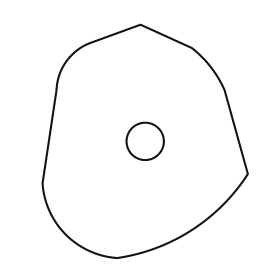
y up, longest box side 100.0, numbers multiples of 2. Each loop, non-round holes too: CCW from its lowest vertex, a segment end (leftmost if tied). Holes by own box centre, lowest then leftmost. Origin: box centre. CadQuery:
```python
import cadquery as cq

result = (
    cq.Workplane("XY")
    .moveTo(-12.0, -50.0)
    .threePointArc((20.0, -38.0), (44.0, -14.0))
    .lineTo(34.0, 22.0)
    .threePointArc((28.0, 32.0), (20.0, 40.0))
    .lineTo(-2.0, 50.0)
    .lineTo(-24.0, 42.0)
    .threePointArc((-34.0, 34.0), (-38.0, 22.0))
    .lineTo(-44.0, -18.0)
    .threePointArc((-34.0, -40.0), (-12.0, -50.0))
    .close()
    .moveTo(0.0, 0.0)
    .circle(8.0)
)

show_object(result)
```